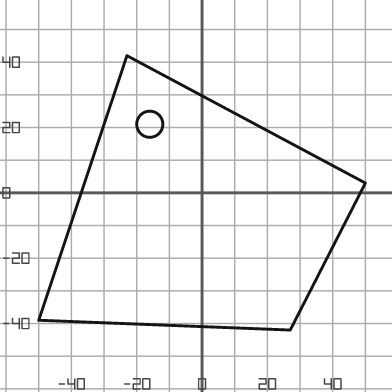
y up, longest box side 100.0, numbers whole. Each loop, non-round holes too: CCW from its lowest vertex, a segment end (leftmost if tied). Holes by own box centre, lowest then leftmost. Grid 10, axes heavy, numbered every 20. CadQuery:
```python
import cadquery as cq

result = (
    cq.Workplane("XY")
    .moveTo(27.0, -42.0)
    .lineTo(50.0, 3.0)
    .lineTo(-23.0, 42.0)
    .lineTo(-50.0, -39.0)
    .close()
    .moveTo(-16.0, 21.0)
    .circle(4.0)
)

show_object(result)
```